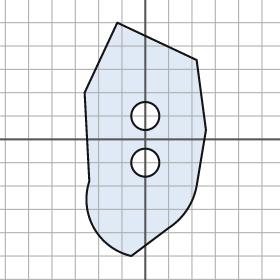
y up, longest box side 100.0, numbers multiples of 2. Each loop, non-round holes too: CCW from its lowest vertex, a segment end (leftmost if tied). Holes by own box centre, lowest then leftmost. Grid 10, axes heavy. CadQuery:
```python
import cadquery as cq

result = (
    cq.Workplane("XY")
    .moveTo(-6.0, -50.0)
    .lineTo(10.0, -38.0)
    .threePointArc((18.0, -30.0), (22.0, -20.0))
    .lineTo(26.0, 4.0)
    .lineTo(22.0, 34.0)
    .lineTo(-12.0, 50.0)
    .lineTo(-26.0, 20.0)
    .lineTo(-24.0, -18.0)
    .threePointArc((-22.0, -38.0), (-6.0, -50.0))
    .close()
    .moveTo(0.0, -10.0)
    .circle(6.0)
    .moveTo(0.0, 10.0)
    .circle(6.0)
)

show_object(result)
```